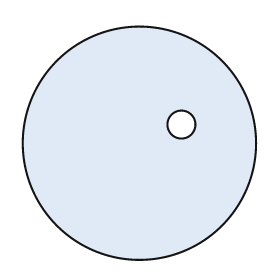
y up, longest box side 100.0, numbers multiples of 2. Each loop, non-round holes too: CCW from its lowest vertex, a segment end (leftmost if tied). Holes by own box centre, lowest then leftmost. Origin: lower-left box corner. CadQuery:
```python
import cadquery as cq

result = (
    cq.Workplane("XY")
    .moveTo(50.0, 50.0)
    .circle(50.0)
    .moveTo(68.0, 58.0)
    .circle(6.0)
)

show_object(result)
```